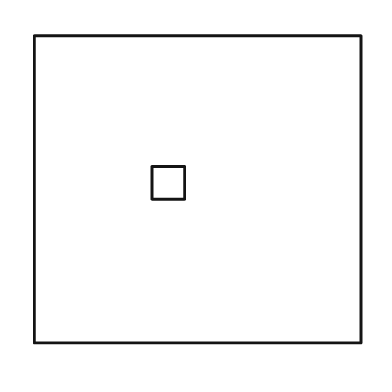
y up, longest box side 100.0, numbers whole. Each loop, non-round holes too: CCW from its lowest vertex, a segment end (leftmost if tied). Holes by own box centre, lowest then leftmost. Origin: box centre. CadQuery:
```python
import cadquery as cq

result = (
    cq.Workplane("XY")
    .moveTo(-50.0, -47.0)
    .lineTo(50.0, -47.0)
    .lineTo(50.0, 47.0)
    .lineTo(-50.0, 47.0)
    .close()
    .moveTo(-14.0, -3.0)
    .lineTo(-4.0, -3.0)
    .lineTo(-4.0, 7.0)
    .lineTo(-14.0, 7.0)
    .close()
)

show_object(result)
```